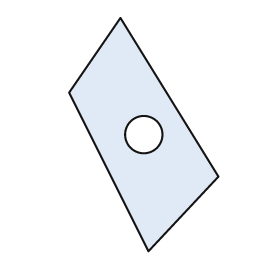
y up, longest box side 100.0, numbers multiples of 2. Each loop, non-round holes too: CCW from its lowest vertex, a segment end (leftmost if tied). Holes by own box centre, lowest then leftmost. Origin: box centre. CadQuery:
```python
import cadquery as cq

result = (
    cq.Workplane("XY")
    .moveTo(2.0, -50.0)
    .lineTo(32.0, -18.0)
    .lineTo(-10.0, 50.0)
    .lineTo(-32.0, 18.0)
    .close()
    .moveTo(0.0, 0.0)
    .circle(8.0)
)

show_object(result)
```